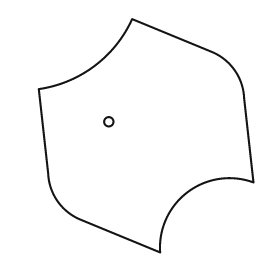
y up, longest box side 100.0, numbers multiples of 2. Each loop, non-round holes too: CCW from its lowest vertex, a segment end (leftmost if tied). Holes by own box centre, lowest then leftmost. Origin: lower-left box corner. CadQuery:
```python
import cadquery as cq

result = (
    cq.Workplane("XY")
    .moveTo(52.0, 0.0)
    .threePointArc((64.0, 26.0), (92.0, 30.0))
    .lineTo(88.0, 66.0)
    .threePointArc((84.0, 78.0), (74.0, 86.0))
    .lineTo(40.0, 100.0)
    .threePointArc((24.0, 80.0), (0.0, 70.0))
    .lineTo(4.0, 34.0)
    .threePointArc((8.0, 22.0), (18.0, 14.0))
    .close()
    .moveTo(30.0, 56.0)
    .circle(2.0)
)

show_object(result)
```